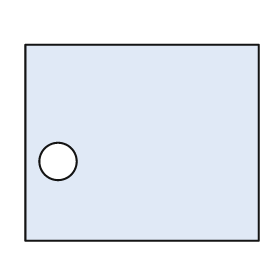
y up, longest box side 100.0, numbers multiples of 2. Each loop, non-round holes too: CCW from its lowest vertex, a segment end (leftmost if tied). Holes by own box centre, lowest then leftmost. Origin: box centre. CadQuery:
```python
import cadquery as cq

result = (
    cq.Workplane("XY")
    .moveTo(-50.0, -42.0)
    .lineTo(50.0, -42.0)
    .lineTo(50.0, 42.0)
    .lineTo(-50.0, 42.0)
    .close()
    .moveTo(-36.0, -8.0)
    .circle(8.0)
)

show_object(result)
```